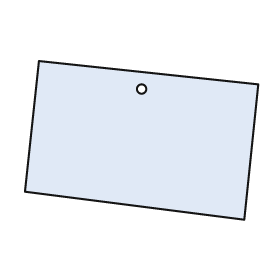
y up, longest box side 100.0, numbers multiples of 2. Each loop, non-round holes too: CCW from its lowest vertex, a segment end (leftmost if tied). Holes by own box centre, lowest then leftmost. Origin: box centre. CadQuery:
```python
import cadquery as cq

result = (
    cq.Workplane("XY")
    .moveTo(44.0, -34.0)
    .lineTo(50.0, 24.0)
    .lineTo(-44.0, 34.0)
    .lineTo(-50.0, -22.0)
    .close()
    .moveTo(0.0, 22.0)
    .circle(2.0)
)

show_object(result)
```